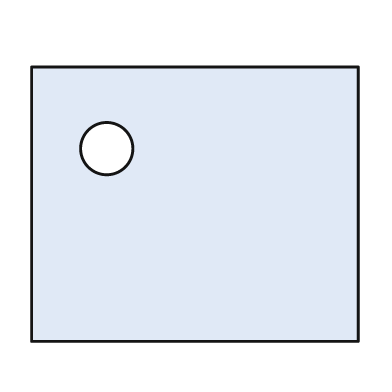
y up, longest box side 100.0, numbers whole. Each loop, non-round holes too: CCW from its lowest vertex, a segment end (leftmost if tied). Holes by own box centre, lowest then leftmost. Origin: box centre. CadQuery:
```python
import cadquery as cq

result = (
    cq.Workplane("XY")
    .moveTo(-50.0, -42.0)
    .lineTo(50.0, -42.0)
    .lineTo(50.0, 42.0)
    .lineTo(-50.0, 42.0)
    .close()
    .moveTo(-27.0, 17.0)
    .circle(8.0)
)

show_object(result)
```